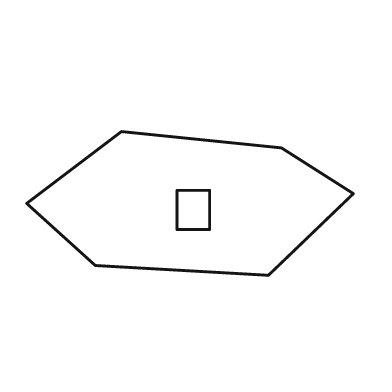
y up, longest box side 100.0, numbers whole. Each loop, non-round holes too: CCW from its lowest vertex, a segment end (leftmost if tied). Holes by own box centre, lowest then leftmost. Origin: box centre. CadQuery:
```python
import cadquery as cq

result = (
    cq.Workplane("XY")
    .moveTo(24.0, -22.0)
    .lineTo(50.0, 3.0)
    .lineTo(28.0, 17.0)
    .lineTo(-21.0, 22.0)
    .lineTo(-50.0, 0.0)
    .lineTo(-29.0, -19.0)
    .close()
    .moveTo(-4.0, -8.0)
    .lineTo(6.0, -8.0)
    .lineTo(6.0, 4.0)
    .lineTo(-4.0, 4.0)
    .close()
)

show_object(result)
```